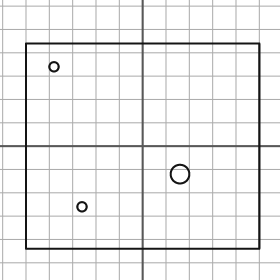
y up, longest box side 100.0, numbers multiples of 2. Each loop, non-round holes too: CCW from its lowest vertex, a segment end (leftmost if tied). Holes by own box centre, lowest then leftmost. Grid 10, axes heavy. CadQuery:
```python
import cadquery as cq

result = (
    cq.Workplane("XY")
    .moveTo(-50.0, -44.0)
    .lineTo(50.0, -44.0)
    .lineTo(50.0, 44.0)
    .lineTo(-50.0, 44.0)
    .close()
    .moveTo(-26.0, -26.0)
    .circle(2.0)
    .moveTo(16.0, -12.0)
    .circle(4.0)
    .moveTo(-38.0, 34.0)
    .circle(2.0)
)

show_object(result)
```